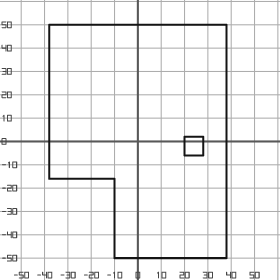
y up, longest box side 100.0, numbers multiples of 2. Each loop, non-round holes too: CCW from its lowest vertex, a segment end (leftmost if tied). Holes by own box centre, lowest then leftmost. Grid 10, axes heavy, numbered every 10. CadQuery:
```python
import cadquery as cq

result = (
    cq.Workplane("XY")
    .moveTo(-10.0, -50.0)
    .lineTo(38.0, -50.0)
    .lineTo(38.0, 50.0)
    .lineTo(-38.0, 50.0)
    .lineTo(-38.0, -16.0)
    .lineTo(-10.0, -16.0)
    .close()
    .moveTo(20.0, -6.0)
    .lineTo(28.0, -6.0)
    .lineTo(28.0, 2.0)
    .lineTo(20.0, 2.0)
    .close()
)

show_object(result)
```